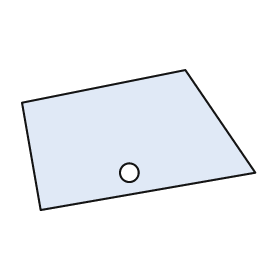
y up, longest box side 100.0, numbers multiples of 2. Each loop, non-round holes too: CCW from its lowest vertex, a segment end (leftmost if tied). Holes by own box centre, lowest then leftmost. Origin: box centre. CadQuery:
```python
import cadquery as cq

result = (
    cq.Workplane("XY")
    .moveTo(-42.0, -30.0)
    .lineTo(50.0, -14.0)
    .lineTo(20.0, 30.0)
    .lineTo(-50.0, 16.0)
    .close()
    .moveTo(-4.0, -14.0)
    .circle(4.0)
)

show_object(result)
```